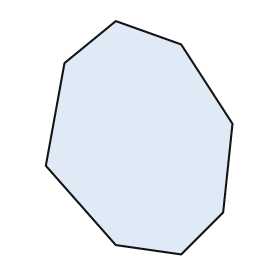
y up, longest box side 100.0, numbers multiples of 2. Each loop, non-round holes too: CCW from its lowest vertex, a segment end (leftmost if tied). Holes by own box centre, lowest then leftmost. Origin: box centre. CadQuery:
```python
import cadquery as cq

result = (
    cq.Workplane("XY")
    .moveTo(18.0, -50.0)
    .lineTo(36.0, -32.0)
    .lineTo(40.0, 6.0)
    .lineTo(18.0, 40.0)
    .lineTo(-10.0, 50.0)
    .lineTo(-32.0, 32.0)
    .lineTo(-40.0, -12.0)
    .lineTo(-10.0, -46.0)
    .close()
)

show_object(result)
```